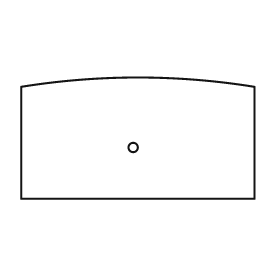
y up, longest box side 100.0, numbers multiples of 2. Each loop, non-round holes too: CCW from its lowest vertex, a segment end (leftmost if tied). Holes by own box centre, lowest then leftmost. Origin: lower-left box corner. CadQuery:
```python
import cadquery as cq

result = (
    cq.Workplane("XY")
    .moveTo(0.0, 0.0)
    .lineTo(100.0, 0.0)
    .lineTo(100.0, 48.0)
    .threePointArc((50.0, 52.0), (0.0, 48.0))
    .close()
    .moveTo(48.0, 22.0)
    .circle(2.0)
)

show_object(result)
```